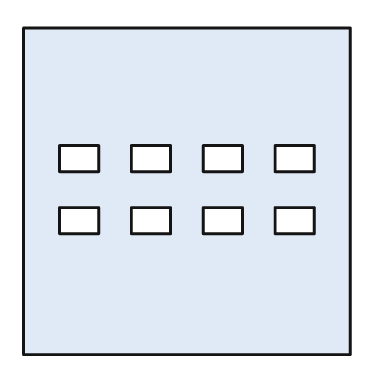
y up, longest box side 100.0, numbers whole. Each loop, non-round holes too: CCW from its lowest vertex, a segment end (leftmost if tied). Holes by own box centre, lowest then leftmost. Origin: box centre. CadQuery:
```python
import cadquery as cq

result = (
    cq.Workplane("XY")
    .moveTo(-50.0, -50.0)
    .lineTo(50.0, -50.0)
    .lineTo(50.0, 50.0)
    .lineTo(-50.0, 50.0)
    .close()
    .moveTo(-39.0, -13.0)
    .lineTo(-27.0, -13.0)
    .lineTo(-27.0, -5.0)
    .lineTo(-39.0, -5.0)
    .close()
    .moveTo(-17.0, -13.0)
    .lineTo(-5.0, -13.0)
    .lineTo(-5.0, -5.0)
    .lineTo(-17.0, -5.0)
    .close()
    .moveTo(5.0, -13.0)
    .lineTo(17.0, -13.0)
    .lineTo(17.0, -5.0)
    .lineTo(5.0, -5.0)
    .close()
    .moveTo(27.0, -13.0)
    .lineTo(39.0, -13.0)
    .lineTo(39.0, -5.0)
    .lineTo(27.0, -5.0)
    .close()
    .moveTo(-39.0, 6.0)
    .lineTo(-27.0, 6.0)
    .lineTo(-27.0, 14.0)
    .lineTo(-39.0, 14.0)
    .close()
    .moveTo(-17.0, 6.0)
    .lineTo(-5.0, 6.0)
    .lineTo(-5.0, 14.0)
    .lineTo(-17.0, 14.0)
    .close()
    .moveTo(5.0, 6.0)
    .lineTo(17.0, 6.0)
    .lineTo(17.0, 14.0)
    .lineTo(5.0, 14.0)
    .close()
    .moveTo(27.0, 6.0)
    .lineTo(39.0, 6.0)
    .lineTo(39.0, 14.0)
    .lineTo(27.0, 14.0)
    .close()
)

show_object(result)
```